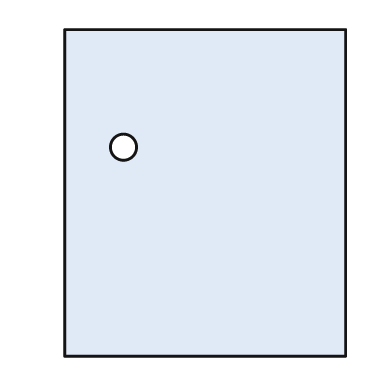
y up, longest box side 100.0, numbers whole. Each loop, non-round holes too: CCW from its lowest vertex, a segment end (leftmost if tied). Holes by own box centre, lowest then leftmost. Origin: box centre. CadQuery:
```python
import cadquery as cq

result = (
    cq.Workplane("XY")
    .moveTo(-43.0, -50.0)
    .lineTo(43.0, -50.0)
    .lineTo(43.0, 50.0)
    .lineTo(-43.0, 50.0)
    .close()
    .moveTo(-25.0, 14.0)
    .circle(4.0)
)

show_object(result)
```